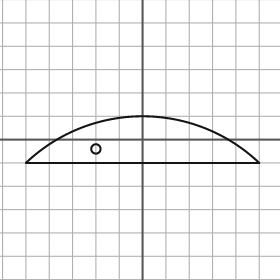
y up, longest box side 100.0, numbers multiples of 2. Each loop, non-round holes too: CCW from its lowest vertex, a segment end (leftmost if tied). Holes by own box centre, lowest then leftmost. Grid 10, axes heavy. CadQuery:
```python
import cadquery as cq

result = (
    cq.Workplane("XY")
    .moveTo(-50.0, -10.0)
    .lineTo(50.0, -10.0)
    .threePointArc((0.0, 10.0), (-50.0, -10.0))
    .close()
    .moveTo(-20.0, -4.0)
    .circle(2.0)
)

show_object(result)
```